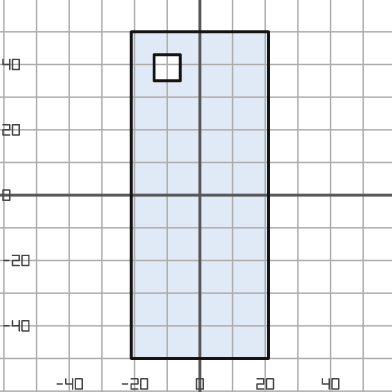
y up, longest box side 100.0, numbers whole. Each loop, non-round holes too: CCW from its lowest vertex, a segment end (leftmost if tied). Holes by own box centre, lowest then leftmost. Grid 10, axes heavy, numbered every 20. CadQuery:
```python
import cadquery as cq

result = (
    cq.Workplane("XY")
    .moveTo(-21.0, -50.0)
    .lineTo(21.0, -50.0)
    .lineTo(21.0, 50.0)
    .lineTo(-21.0, 50.0)
    .close()
    .moveTo(-14.0, 35.0)
    .lineTo(-6.0, 35.0)
    .lineTo(-6.0, 43.0)
    .lineTo(-14.0, 43.0)
    .close()
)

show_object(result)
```